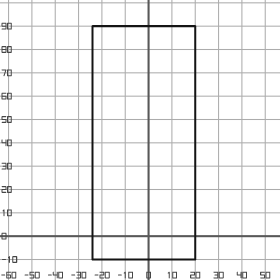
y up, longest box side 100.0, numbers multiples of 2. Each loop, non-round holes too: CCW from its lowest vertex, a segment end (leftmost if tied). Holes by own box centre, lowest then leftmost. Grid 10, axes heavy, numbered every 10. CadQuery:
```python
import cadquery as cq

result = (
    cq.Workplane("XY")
    .moveTo(-24.0, -10.0)
    .lineTo(20.0, -10.0)
    .lineTo(20.0, 90.0)
    .lineTo(-24.0, 90.0)
    .close()
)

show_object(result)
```